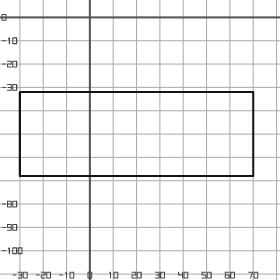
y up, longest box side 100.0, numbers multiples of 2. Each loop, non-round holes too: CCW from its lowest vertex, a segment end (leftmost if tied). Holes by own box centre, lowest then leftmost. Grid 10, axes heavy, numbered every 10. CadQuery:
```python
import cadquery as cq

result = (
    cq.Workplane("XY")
    .moveTo(-30.0, -68.0)
    .lineTo(70.0, -68.0)
    .lineTo(70.0, -32.0)
    .lineTo(-30.0, -32.0)
    .close()
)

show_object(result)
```